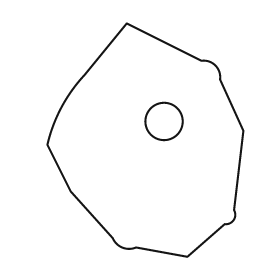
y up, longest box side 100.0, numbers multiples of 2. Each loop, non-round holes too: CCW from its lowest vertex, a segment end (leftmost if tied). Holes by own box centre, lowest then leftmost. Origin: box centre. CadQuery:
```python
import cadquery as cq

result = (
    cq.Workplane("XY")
    .moveTo(18.0, -50.0)
    .lineTo(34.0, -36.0)
    .threePointArc((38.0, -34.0), (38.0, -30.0))
    .lineTo(42.0, 4.0)
    .lineTo(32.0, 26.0)
    .threePointArc((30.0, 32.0), (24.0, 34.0))
    .lineTo(-8.0, 50.0)
    .lineTo(-26.0, 28.0)
    .threePointArc((-36.0, 14.0), (-42.0, -2.0))
    .lineTo(-32.0, -22.0)
    .lineTo(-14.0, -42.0)
    .threePointArc((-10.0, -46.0), (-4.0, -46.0))
    .close()
    .moveTo(8.0, 8.0)
    .circle(8.0)
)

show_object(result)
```